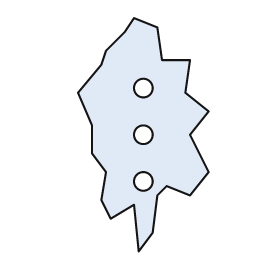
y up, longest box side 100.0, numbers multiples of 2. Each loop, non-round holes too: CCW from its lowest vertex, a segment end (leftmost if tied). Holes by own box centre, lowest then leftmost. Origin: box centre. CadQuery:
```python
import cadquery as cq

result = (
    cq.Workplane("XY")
    .moveTo(-2.0, -50.0)
    .lineTo(4.0, -42.0)
    .lineTo(6.0, -26.0)
    .lineTo(10.0, -22.0)
    .lineTo(20.0, -26.0)
    .lineTo(28.0, -16.0)
    .lineTo(20.0, 0.0)
    .lineTo(28.0, 10.0)
    .lineTo(18.0, 18.0)
    .lineTo(20.0, 32.0)
    .lineTo(8.0, 32.0)
    .lineTo(6.0, 46.0)
    .lineTo(-4.0, 50.0)
    .lineTo(-8.0, 44.0)
    .lineTo(-16.0, 36.0)
    .lineTo(-18.0, 30.0)
    .lineTo(-28.0, 18.0)
    .lineTo(-22.0, 4.0)
    .lineTo(-22.0, -8.0)
    .lineTo(-16.0, -16.0)
    .lineTo(-18.0, -28.0)
    .lineTo(-14.0, -36.0)
    .lineTo(-4.0, -30.0)
    .close()
    .moveTo(0.0, -20.0)
    .circle(4.0)
    .moveTo(0.0, 0.0)
    .circle(4.0)
    .moveTo(0.0, 20.0)
    .circle(4.0)
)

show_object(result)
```